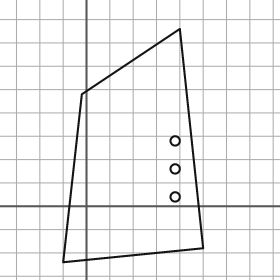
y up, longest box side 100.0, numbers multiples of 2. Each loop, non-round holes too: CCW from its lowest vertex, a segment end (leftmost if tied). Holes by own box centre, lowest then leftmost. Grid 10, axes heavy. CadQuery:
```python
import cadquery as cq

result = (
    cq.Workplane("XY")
    .moveTo(-10.0, -24.0)
    .lineTo(50.0, -18.0)
    .lineTo(40.0, 76.0)
    .lineTo(-2.0, 48.0)
    .close()
    .moveTo(38.0, 4.0)
    .circle(2.0)
    .moveTo(38.0, 16.0)
    .circle(2.0)
    .moveTo(38.0, 28.0)
    .circle(2.0)
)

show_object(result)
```